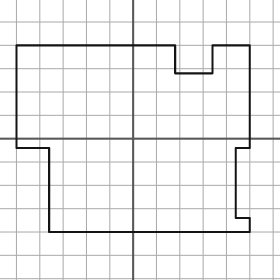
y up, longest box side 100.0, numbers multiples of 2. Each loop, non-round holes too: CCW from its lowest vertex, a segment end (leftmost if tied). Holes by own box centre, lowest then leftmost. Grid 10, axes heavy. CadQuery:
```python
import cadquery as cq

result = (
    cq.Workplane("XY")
    .moveTo(-36.0, -40.0)
    .lineTo(50.0, -40.0)
    .lineTo(50.0, -34.0)
    .lineTo(44.0, -34.0)
    .lineTo(44.0, -4.0)
    .lineTo(50.0, -4.0)
    .lineTo(50.0, 40.0)
    .lineTo(34.0, 40.0)
    .lineTo(34.0, 28.0)
    .lineTo(18.0, 28.0)
    .lineTo(18.0, 40.0)
    .lineTo(-50.0, 40.0)
    .lineTo(-50.0, -4.0)
    .lineTo(-36.0, -4.0)
    .close()
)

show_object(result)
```